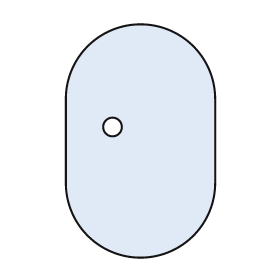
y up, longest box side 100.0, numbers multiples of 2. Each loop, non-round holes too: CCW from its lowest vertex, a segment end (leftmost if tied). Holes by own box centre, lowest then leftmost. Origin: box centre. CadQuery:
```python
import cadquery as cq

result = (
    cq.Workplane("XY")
    .moveTo(-32.0, -18.0)
    .threePointArc((0.0, -50.0), (32.0, -18.0))
    .lineTo(32.0, 18.0)
    .threePointArc((0.0, 50.0), (-32.0, 18.0))
    .close()
    .moveTo(-12.0, 6.0)
    .circle(4.0)
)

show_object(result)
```